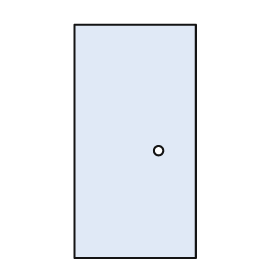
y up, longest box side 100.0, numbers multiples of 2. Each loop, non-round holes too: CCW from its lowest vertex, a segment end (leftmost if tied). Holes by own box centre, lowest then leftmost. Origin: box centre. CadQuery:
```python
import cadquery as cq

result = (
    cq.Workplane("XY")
    .moveTo(-26.0, -50.0)
    .lineTo(26.0, -50.0)
    .lineTo(26.0, 50.0)
    .lineTo(-26.0, 50.0)
    .close()
    .moveTo(10.0, -4.0)
    .circle(2.0)
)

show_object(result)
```